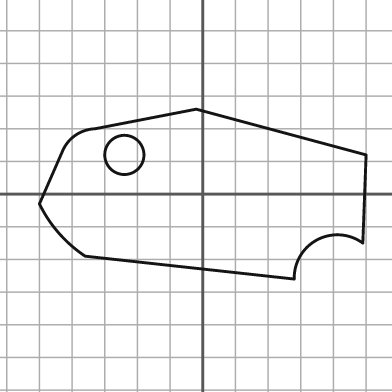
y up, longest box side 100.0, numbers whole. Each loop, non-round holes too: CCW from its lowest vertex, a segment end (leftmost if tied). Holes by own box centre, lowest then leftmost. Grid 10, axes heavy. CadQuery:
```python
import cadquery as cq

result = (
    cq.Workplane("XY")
    .moveTo(28.0, -26.0)
    .threePointArc((35.0, -14.0), (49.0, -15.0))
    .lineTo(50.0, 12.0)
    .lineTo(-2.0, 26.0)
    .lineTo(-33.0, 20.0)
    .threePointArc((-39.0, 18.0), (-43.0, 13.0))
    .lineTo(-50.0, -3.0)
    .threePointArc((-44.0, -12.0), (-36.0, -19.0))
    .close()
    .moveTo(-24.0, 12.0)
    .circle(6.0)
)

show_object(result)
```